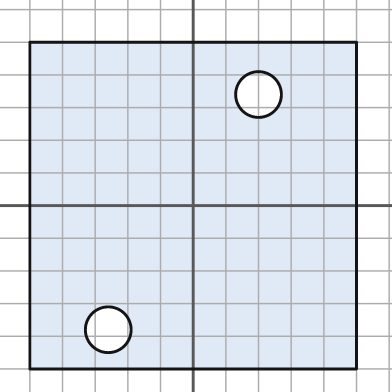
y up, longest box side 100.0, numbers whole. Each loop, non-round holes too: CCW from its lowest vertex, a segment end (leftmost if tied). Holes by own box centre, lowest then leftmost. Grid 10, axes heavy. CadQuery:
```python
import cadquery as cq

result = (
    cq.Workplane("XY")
    .moveTo(-50.0, -50.0)
    .lineTo(50.0, -50.0)
    .lineTo(50.0, 50.0)
    .lineTo(-50.0, 50.0)
    .close()
    .moveTo(-26.0, -38.0)
    .circle(7.0)
    .moveTo(20.0, 34.0)
    .circle(7.0)
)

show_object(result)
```